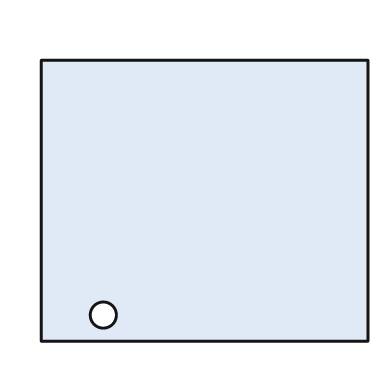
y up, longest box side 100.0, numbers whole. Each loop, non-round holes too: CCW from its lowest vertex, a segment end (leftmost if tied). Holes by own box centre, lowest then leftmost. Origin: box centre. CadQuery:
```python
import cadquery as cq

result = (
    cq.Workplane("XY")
    .moveTo(-50.0, -43.0)
    .lineTo(50.0, -43.0)
    .lineTo(50.0, 43.0)
    .lineTo(-50.0, 43.0)
    .close()
    .moveTo(-31.0, -35.0)
    .circle(4.0)
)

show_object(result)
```